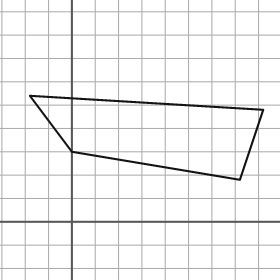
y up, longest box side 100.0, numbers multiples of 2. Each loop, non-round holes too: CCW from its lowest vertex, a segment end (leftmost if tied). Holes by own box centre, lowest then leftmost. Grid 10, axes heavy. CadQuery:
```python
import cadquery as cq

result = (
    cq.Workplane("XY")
    .moveTo(72.0, 18.0)
    .lineTo(82.0, 48.0)
    .lineTo(-18.0, 54.0)
    .lineTo(0.0, 30.0)
    .close()
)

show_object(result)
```